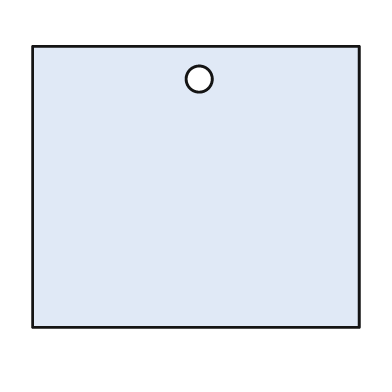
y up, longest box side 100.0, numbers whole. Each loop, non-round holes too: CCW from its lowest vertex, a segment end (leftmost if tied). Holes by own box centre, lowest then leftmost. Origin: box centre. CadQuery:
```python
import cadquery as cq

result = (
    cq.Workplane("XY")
    .moveTo(-50.0, -43.0)
    .lineTo(50.0, -43.0)
    .lineTo(50.0, 43.0)
    .lineTo(-50.0, 43.0)
    .close()
    .moveTo(1.0, 33.0)
    .circle(4.0)
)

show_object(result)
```